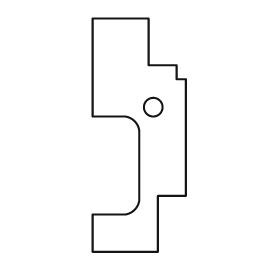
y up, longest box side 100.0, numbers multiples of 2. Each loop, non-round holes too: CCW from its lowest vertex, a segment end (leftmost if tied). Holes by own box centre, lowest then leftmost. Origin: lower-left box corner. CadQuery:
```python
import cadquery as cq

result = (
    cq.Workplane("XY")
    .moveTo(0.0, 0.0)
    .lineTo(28.0, 0.0)
    .lineTo(28.0, 24.0)
    .lineTo(40.0, 24.0)
    .lineTo(40.0, 74.0)
    .lineTo(36.0, 74.0)
    .lineTo(36.0, 80.0)
    .lineTo(24.0, 80.0)
    .lineTo(24.0, 100.0)
    .lineTo(0.0, 100.0)
    .lineTo(0.0, 58.0)
    .lineTo(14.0, 58.0)
    .threePointArc((18.0, 56.0), (20.0, 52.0))
    .lineTo(20.0, 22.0)
    .threePointArc((18.0, 18.0), (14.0, 16.0))
    .lineTo(0.0, 16.0)
    .close()
    .moveTo(26.0, 62.0)
    .circle(4.0)
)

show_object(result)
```